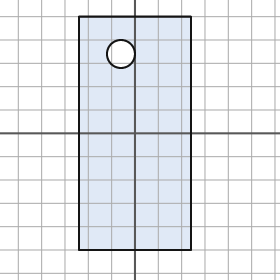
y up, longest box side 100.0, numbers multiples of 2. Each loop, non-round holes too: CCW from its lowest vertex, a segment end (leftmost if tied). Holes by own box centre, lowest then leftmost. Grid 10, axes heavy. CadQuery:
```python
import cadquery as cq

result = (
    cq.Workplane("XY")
    .moveTo(-24.0, -50.0)
    .lineTo(24.0, -50.0)
    .lineTo(24.0, 50.0)
    .lineTo(-24.0, 50.0)
    .close()
    .moveTo(-6.0, 34.0)
    .circle(6.0)
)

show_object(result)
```